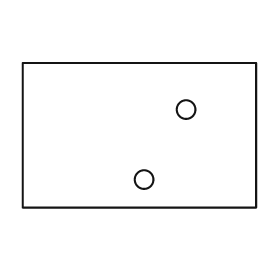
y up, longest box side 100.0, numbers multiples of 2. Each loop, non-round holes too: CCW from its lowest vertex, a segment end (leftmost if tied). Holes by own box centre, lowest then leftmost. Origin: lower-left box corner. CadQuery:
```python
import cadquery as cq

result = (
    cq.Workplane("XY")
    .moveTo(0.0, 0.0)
    .lineTo(100.0, 0.0)
    .lineTo(100.0, 62.0)
    .lineTo(0.0, 62.0)
    .close()
    .moveTo(52.0, 12.0)
    .circle(4.0)
    .moveTo(70.0, 42.0)
    .circle(4.0)
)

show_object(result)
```